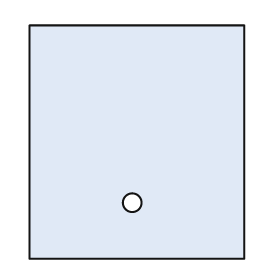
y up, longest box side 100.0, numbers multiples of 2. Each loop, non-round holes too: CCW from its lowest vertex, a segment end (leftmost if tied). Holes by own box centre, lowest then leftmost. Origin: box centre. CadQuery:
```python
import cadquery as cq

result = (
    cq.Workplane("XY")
    .moveTo(-46.0, -50.0)
    .lineTo(46.0, -50.0)
    .lineTo(46.0, 50.0)
    .lineTo(-46.0, 50.0)
    .close()
    .moveTo(-2.0, -26.0)
    .circle(4.0)
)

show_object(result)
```